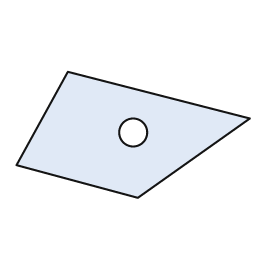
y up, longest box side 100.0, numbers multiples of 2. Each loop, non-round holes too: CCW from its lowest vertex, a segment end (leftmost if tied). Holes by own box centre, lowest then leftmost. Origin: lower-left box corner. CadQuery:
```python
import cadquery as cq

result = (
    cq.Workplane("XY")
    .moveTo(52.0, 0.0)
    .lineTo(100.0, 34.0)
    .lineTo(22.0, 54.0)
    .lineTo(0.0, 14.0)
    .close()
    .moveTo(50.0, 28.0)
    .circle(6.0)
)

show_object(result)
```